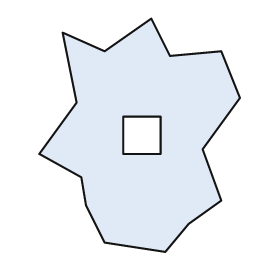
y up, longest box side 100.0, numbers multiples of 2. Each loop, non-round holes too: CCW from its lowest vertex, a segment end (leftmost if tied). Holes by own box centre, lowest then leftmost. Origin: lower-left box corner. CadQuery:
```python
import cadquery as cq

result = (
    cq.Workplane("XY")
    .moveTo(54.0, 0.0)
    .lineTo(64.0, 12.0)
    .lineTo(78.0, 22.0)
    .lineTo(70.0, 44.0)
    .lineTo(86.0, 66.0)
    .lineTo(78.0, 86.0)
    .lineTo(56.0, 84.0)
    .lineTo(48.0, 100.0)
    .lineTo(28.0, 86.0)
    .lineTo(10.0, 94.0)
    .lineTo(16.0, 64.0)
    .lineTo(0.0, 42.0)
    .lineTo(18.0, 32.0)
    .lineTo(20.0, 20.0)
    .lineTo(28.0, 4.0)
    .close()
    .moveTo(36.0, 42.0)
    .lineTo(52.0, 42.0)
    .lineTo(52.0, 58.0)
    .lineTo(36.0, 58.0)
    .close()
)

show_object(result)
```